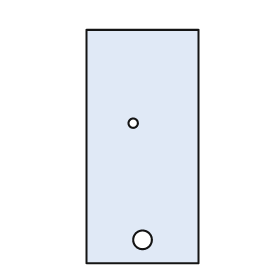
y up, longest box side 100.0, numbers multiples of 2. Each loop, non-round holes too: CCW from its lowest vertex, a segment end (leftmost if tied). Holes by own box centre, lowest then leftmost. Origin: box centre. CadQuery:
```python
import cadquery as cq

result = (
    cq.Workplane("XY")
    .moveTo(-24.0, -50.0)
    .lineTo(24.0, -50.0)
    .lineTo(24.0, 50.0)
    .lineTo(-24.0, 50.0)
    .close()
    .moveTo(0.0, -40.0)
    .circle(4.0)
    .moveTo(-4.0, 10.0)
    .circle(2.0)
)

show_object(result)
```